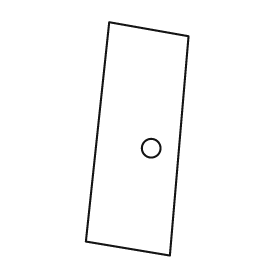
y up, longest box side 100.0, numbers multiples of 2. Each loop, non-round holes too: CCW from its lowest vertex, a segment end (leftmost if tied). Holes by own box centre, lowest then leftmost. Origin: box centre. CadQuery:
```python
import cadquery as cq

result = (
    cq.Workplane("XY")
    .moveTo(14.0, -50.0)
    .lineTo(22.0, 44.0)
    .lineTo(-12.0, 50.0)
    .lineTo(-22.0, -44.0)
    .close()
    .moveTo(6.0, -4.0)
    .circle(4.0)
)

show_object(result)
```